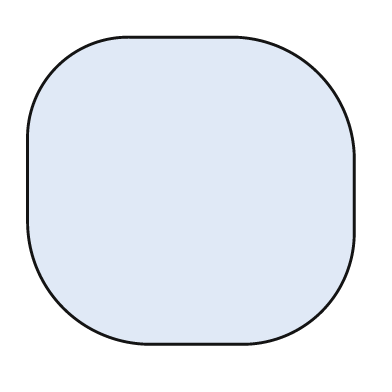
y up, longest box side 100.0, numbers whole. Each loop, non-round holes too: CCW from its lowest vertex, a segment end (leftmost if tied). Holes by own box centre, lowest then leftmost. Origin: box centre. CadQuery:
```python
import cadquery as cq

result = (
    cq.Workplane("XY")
    .moveTo(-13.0, -47.0)
    .lineTo(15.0, -47.0)
    .threePointArc((40.0, -37.0), (50.0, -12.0))
    .lineTo(50.0, 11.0)
    .threePointArc((39.0, 36.0), (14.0, 47.0))
    .lineTo(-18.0, 47.0)
    .threePointArc((-41.0, 38.0), (-50.0, 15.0))
    .lineTo(-50.0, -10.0)
    .threePointArc((-39.0, -36.0), (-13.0, -47.0))
    .close()
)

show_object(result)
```